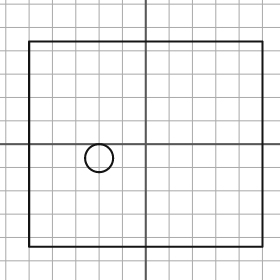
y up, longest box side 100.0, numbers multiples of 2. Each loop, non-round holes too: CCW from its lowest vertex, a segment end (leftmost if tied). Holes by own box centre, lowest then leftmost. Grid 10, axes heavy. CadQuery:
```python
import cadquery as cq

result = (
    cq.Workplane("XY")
    .moveTo(-50.0, -44.0)
    .lineTo(50.0, -44.0)
    .lineTo(50.0, 44.0)
    .lineTo(-50.0, 44.0)
    .close()
    .moveTo(-20.0, -6.0)
    .circle(6.0)
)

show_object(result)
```